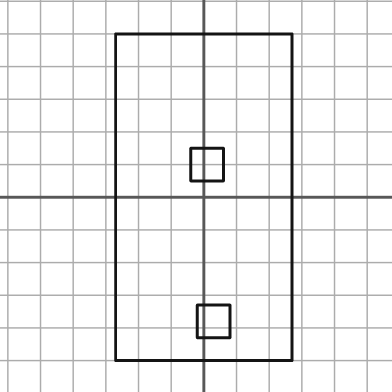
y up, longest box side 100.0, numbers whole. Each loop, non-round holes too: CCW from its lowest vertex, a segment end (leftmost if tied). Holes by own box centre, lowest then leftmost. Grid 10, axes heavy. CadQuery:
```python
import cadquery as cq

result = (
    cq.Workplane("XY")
    .moveTo(-27.0, -50.0)
    .lineTo(27.0, -50.0)
    .lineTo(27.0, 50.0)
    .lineTo(-27.0, 50.0)
    .close()
    .moveTo(-2.0, -43.0)
    .lineTo(8.0, -43.0)
    .lineTo(8.0, -33.0)
    .lineTo(-2.0, -33.0)
    .close()
    .moveTo(-4.0, 5.0)
    .lineTo(6.0, 5.0)
    .lineTo(6.0, 15.0)
    .lineTo(-4.0, 15.0)
    .close()
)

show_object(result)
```